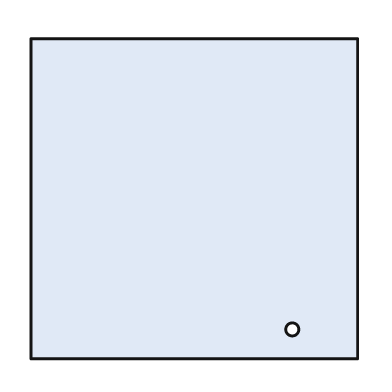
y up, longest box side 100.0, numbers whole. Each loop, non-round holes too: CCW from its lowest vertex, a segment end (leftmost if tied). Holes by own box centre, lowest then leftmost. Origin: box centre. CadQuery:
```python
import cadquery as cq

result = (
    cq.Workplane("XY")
    .moveTo(-50.0, -49.0)
    .lineTo(50.0, -49.0)
    .lineTo(50.0, 49.0)
    .lineTo(-50.0, 49.0)
    .close()
    .moveTo(30.0, -40.0)
    .circle(2.0)
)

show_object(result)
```